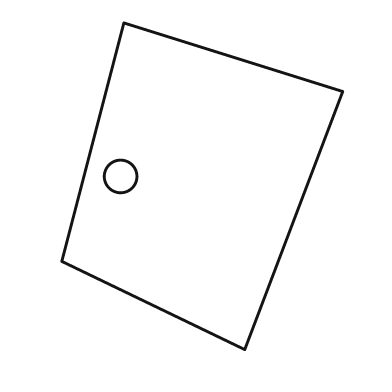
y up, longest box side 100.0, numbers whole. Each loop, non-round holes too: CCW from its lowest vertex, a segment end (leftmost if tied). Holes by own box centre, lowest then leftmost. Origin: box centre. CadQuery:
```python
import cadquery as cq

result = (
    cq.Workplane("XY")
    .moveTo(13.0, -50.0)
    .lineTo(43.0, 29.0)
    .lineTo(-24.0, 50.0)
    .lineTo(-43.0, -23.0)
    .close()
    .moveTo(-25.0, 3.0)
    .circle(5.0)
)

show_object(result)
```